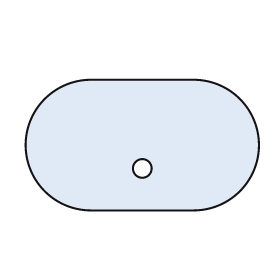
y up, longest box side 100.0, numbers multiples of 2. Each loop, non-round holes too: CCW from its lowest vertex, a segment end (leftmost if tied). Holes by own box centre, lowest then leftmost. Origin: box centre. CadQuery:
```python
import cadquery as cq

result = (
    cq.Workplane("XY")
    .moveTo(-22.0, -28.0)
    .lineTo(22.0, -28.0)
    .threePointArc((50.0, 0.0), (22.0, 28.0))
    .lineTo(-22.0, 28.0)
    .threePointArc((-50.0, 0.0), (-22.0, -28.0))
    .close()
    .moveTo(0.0, -10.0)
    .circle(4.0)
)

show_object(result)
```